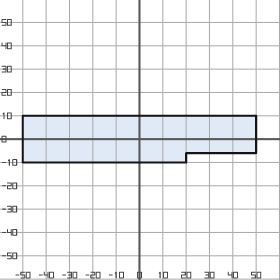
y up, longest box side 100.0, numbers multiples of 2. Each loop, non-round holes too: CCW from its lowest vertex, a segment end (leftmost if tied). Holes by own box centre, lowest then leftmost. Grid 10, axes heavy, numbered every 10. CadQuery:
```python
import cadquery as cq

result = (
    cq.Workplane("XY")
    .moveTo(-50.0, -10.0)
    .lineTo(20.0, -10.0)
    .lineTo(20.0, -6.0)
    .lineTo(50.0, -6.0)
    .lineTo(50.0, 10.0)
    .lineTo(-50.0, 10.0)
    .close()
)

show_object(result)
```